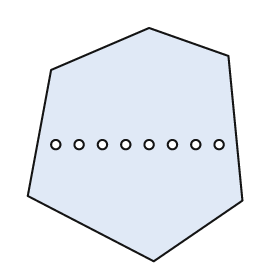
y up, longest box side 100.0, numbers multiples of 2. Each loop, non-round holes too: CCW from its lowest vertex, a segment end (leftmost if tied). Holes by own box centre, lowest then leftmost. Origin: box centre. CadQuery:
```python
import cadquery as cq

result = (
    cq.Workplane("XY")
    .moveTo(8.0, -50.0)
    .lineTo(46.0, -24.0)
    .lineTo(40.0, 38.0)
    .lineTo(6.0, 50.0)
    .lineTo(-36.0, 32.0)
    .lineTo(-46.0, -22.0)
    .close()
    .moveTo(-34.0, 0.0)
    .circle(2.0)
    .moveTo(-24.0, 0.0)
    .circle(2.0)
    .moveTo(-14.0, 0.0)
    .circle(2.0)
    .moveTo(-4.0, 0.0)
    .circle(2.0)
    .moveTo(6.0, 0.0)
    .circle(2.0)
    .moveTo(16.0, 0.0)
    .circle(2.0)
    .moveTo(26.0, 0.0)
    .circle(2.0)
    .moveTo(36.0, 0.0)
    .circle(2.0)
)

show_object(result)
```